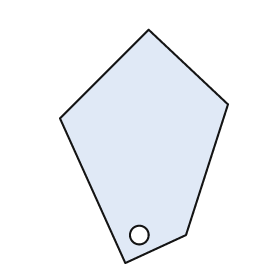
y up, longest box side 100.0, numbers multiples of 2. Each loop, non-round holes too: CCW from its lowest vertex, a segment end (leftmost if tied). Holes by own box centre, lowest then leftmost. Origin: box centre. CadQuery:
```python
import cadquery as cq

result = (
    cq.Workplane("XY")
    .moveTo(-8.0, -50.0)
    .lineTo(18.0, -38.0)
    .lineTo(36.0, 18.0)
    .lineTo(2.0, 50.0)
    .lineTo(-36.0, 12.0)
    .close()
    .moveTo(-2.0, -38.0)
    .circle(4.0)
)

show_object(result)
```